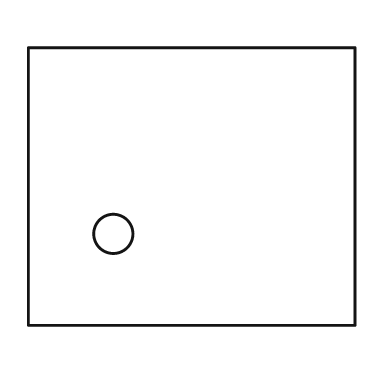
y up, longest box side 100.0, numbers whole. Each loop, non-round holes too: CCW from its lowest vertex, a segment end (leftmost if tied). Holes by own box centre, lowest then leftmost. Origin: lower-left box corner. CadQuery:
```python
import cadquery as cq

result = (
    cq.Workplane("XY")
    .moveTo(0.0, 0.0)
    .lineTo(100.0, 0.0)
    .lineTo(100.0, 85.0)
    .lineTo(0.0, 85.0)
    .close()
    .moveTo(26.0, 28.0)
    .circle(6.0)
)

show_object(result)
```